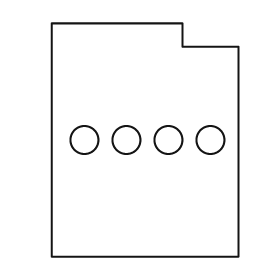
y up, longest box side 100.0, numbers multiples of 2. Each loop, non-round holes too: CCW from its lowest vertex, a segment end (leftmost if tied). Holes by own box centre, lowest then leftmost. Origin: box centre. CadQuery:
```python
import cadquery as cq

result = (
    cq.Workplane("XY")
    .moveTo(-40.0, -50.0)
    .lineTo(40.0, -50.0)
    .lineTo(40.0, 40.0)
    .lineTo(16.0, 40.0)
    .lineTo(16.0, 50.0)
    .lineTo(-40.0, 50.0)
    .close()
    .moveTo(-26.0, 0.0)
    .circle(6.0)
    .moveTo(-8.0, 0.0)
    .circle(6.0)
    .moveTo(10.0, 0.0)
    .circle(6.0)
    .moveTo(28.0, 0.0)
    .circle(6.0)
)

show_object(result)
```